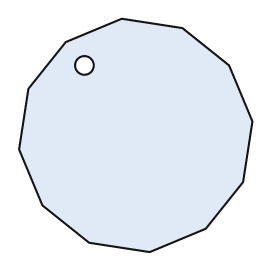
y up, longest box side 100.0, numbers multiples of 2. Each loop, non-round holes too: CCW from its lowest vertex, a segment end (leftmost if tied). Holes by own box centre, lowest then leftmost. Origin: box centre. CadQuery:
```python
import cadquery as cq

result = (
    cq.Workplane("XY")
    .moveTo(6.0, -50.0)
    .lineTo(30.0, -40.0)
    .lineTo(46.0, -20.0)
    .lineTo(50.0, 6.0)
    .lineTo(40.0, 30.0)
    .lineTo(20.0, 46.0)
    .lineTo(-6.0, 50.0)
    .lineTo(-30.0, 40.0)
    .lineTo(-46.0, 20.0)
    .lineTo(-50.0, -6.0)
    .lineTo(-40.0, -30.0)
    .lineTo(-20.0, -46.0)
    .close()
    .moveTo(-22.0, 30.0)
    .circle(4.0)
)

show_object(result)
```